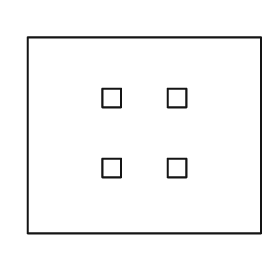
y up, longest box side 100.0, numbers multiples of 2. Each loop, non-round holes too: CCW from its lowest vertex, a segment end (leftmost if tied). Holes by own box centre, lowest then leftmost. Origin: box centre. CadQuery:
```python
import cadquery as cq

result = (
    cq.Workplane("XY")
    .moveTo(-50.0, -42.0)
    .lineTo(50.0, -42.0)
    .lineTo(50.0, 42.0)
    .lineTo(-50.0, 42.0)
    .close()
    .moveTo(-18.0, -18.0)
    .lineTo(-10.0, -18.0)
    .lineTo(-10.0, -10.0)
    .lineTo(-18.0, -10.0)
    .close()
    .moveTo(10.0, -18.0)
    .lineTo(18.0, -18.0)
    .lineTo(18.0, -10.0)
    .lineTo(10.0, -10.0)
    .close()
    .moveTo(-18.0, 12.0)
    .lineTo(-10.0, 12.0)
    .lineTo(-10.0, 20.0)
    .lineTo(-18.0, 20.0)
    .close()
    .moveTo(10.0, 12.0)
    .lineTo(18.0, 12.0)
    .lineTo(18.0, 20.0)
    .lineTo(10.0, 20.0)
    .close()
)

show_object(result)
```